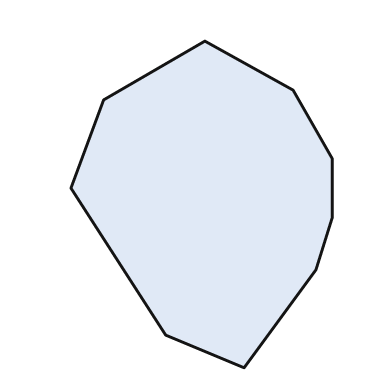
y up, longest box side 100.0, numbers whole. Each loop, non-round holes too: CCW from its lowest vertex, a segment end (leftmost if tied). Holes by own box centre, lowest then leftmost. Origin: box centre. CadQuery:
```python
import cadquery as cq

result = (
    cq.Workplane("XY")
    .moveTo(13.0, -50.0)
    .lineTo(35.0, -20.0)
    .lineTo(40.0, -4.0)
    .lineTo(40.0, 14.0)
    .lineTo(28.0, 35.0)
    .lineTo(1.0, 50.0)
    .lineTo(-30.0, 32.0)
    .lineTo(-40.0, 5.0)
    .lineTo(-11.0, -40.0)
    .close()
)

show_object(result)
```